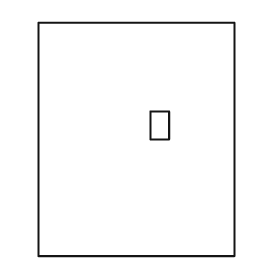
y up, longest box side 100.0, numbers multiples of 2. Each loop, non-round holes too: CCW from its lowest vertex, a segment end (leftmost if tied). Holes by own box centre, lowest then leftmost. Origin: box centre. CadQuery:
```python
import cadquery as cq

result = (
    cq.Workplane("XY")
    .moveTo(-42.0, -50.0)
    .lineTo(42.0, -50.0)
    .lineTo(42.0, 50.0)
    .lineTo(-42.0, 50.0)
    .close()
    .moveTo(6.0, 0.0)
    .lineTo(14.0, 0.0)
    .lineTo(14.0, 12.0)
    .lineTo(6.0, 12.0)
    .close()
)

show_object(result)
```